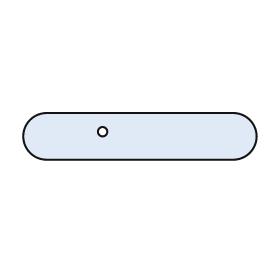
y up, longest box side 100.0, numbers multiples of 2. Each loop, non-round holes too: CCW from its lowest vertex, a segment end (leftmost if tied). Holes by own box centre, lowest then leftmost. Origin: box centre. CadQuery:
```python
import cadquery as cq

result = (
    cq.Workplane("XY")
    .moveTo(-40.0, -10.0)
    .lineTo(40.0, -10.0)
    .threePointArc((50.0, 0.0), (40.0, 10.0))
    .lineTo(-40.0, 10.0)
    .threePointArc((-50.0, 0.0), (-40.0, -10.0))
    .close()
    .moveTo(-16.0, 2.0)
    .circle(2.0)
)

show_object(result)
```